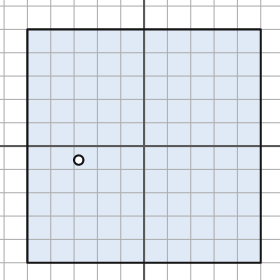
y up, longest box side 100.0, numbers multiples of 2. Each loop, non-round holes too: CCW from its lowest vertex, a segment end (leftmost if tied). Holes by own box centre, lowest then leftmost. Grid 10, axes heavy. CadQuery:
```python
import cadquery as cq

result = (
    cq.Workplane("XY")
    .moveTo(-50.0, -50.0)
    .lineTo(50.0, -50.0)
    .lineTo(50.0, 50.0)
    .lineTo(-50.0, 50.0)
    .close()
    .moveTo(-28.0, -6.0)
    .circle(2.0)
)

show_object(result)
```